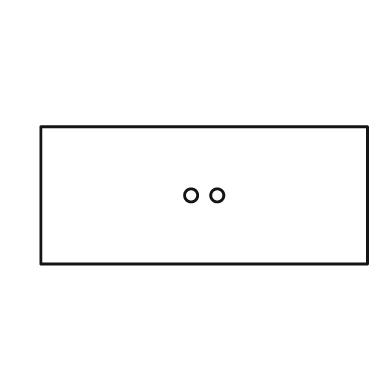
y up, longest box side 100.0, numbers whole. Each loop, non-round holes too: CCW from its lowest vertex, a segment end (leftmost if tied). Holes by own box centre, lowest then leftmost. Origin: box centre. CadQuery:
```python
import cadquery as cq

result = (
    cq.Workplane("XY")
    .moveTo(-50.0, -21.0)
    .lineTo(50.0, -21.0)
    .lineTo(50.0, 21.0)
    .lineTo(-50.0, 21.0)
    .close()
    .moveTo(-4.0, 0.0)
    .circle(2.0)
    .moveTo(4.0, 0.0)
    .circle(2.0)
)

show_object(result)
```